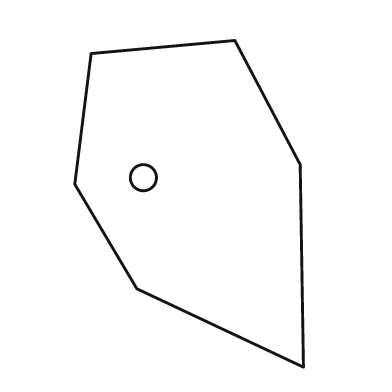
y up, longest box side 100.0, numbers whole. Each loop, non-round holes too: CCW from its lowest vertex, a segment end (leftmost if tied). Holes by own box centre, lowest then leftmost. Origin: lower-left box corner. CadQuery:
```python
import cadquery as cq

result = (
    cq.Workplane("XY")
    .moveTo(70.0, 0.0)
    .lineTo(69.0, 62.0)
    .lineTo(49.0, 100.0)
    .lineTo(5.0, 96.0)
    .lineTo(0.0, 56.0)
    .lineTo(19.0, 24.0)
    .close()
    .moveTo(21.0, 58.0)
    .circle(4.0)
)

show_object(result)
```